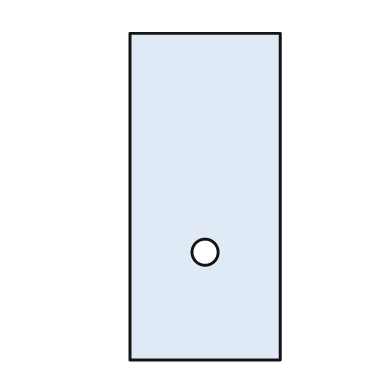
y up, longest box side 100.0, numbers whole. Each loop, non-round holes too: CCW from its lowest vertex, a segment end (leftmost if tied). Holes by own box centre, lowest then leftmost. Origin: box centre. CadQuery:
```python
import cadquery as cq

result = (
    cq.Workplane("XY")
    .moveTo(-23.0, -50.0)
    .lineTo(23.0, -50.0)
    .lineTo(23.0, 50.0)
    .lineTo(-23.0, 50.0)
    .close()
    .moveTo(0.0, -17.0)
    .circle(4.0)
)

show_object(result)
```